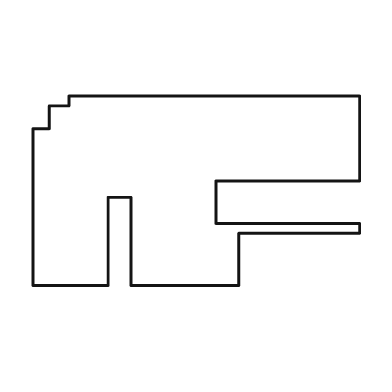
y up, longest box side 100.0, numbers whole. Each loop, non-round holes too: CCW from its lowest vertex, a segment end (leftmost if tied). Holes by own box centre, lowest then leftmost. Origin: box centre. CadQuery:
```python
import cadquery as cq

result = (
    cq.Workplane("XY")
    .moveTo(-50.0, -29.0)
    .lineTo(-27.0, -29.0)
    .lineTo(-27.0, -2.0)
    .lineTo(-20.0, -2.0)
    .lineTo(-20.0, -29.0)
    .lineTo(13.0, -29.0)
    .lineTo(13.0, -13.0)
    .lineTo(50.0, -13.0)
    .lineTo(50.0, -10.0)
    .lineTo(6.0, -10.0)
    .lineTo(6.0, 3.0)
    .lineTo(50.0, 3.0)
    .lineTo(50.0, 29.0)
    .lineTo(-39.0, 29.0)
    .lineTo(-39.0, 26.0)
    .lineTo(-45.0, 26.0)
    .lineTo(-45.0, 19.0)
    .lineTo(-50.0, 19.0)
    .close()
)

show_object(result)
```